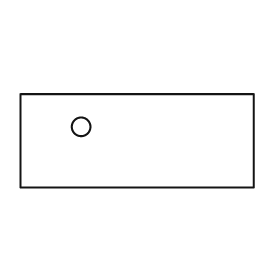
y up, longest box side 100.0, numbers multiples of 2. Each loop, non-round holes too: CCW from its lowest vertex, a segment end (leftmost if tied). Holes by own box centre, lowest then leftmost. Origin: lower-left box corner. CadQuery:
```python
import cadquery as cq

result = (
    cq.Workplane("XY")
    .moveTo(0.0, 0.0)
    .lineTo(100.0, 0.0)
    .lineTo(100.0, 40.0)
    .lineTo(0.0, 40.0)
    .close()
    .moveTo(26.0, 26.0)
    .circle(4.0)
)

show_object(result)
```